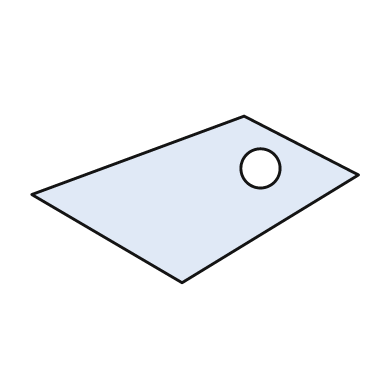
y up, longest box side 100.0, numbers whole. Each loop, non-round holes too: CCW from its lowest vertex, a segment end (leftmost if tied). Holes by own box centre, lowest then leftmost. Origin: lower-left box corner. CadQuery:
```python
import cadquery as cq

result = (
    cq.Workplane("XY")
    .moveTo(46.0, 0.0)
    .lineTo(100.0, 33.0)
    .lineTo(65.0, 51.0)
    .lineTo(0.0, 27.0)
    .close()
    .moveTo(70.0, 35.0)
    .circle(6.0)
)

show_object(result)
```